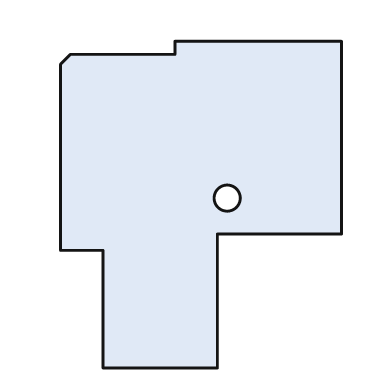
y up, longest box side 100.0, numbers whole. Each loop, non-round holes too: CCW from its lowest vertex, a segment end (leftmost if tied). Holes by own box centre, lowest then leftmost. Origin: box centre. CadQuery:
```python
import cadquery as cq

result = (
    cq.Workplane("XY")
    .moveTo(-30.0, -50.0)
    .lineTo(5.0, -50.0)
    .lineTo(5.0, -9.0)
    .lineTo(43.0, -9.0)
    .lineTo(43.0, 50.0)
    .lineTo(-8.0, 50.0)
    .lineTo(-8.0, 46.0)
    .lineTo(-40.0, 46.0)
    .lineTo(-43.0, 43.0)
    .lineTo(-43.0, -14.0)
    .lineTo(-30.0, -14.0)
    .close()
    .moveTo(8.0, 2.0)
    .circle(4.0)
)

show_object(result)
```